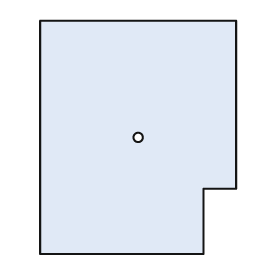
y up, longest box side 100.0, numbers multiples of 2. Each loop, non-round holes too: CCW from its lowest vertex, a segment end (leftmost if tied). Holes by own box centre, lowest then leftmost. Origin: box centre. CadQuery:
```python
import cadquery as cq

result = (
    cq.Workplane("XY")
    .moveTo(-42.0, -50.0)
    .lineTo(28.0, -50.0)
    .lineTo(28.0, -22.0)
    .lineTo(42.0, -22.0)
    .lineTo(42.0, 50.0)
    .lineTo(-42.0, 50.0)
    .close()
    .moveTo(0.0, 0.0)
    .circle(2.0)
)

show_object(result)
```